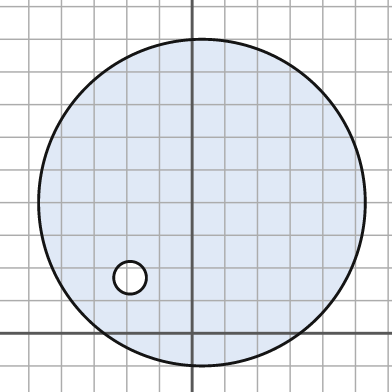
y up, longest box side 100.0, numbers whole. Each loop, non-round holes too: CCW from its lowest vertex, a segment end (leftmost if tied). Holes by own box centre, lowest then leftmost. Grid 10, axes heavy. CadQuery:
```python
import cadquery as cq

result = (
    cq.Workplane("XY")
    .moveTo(3.0, 40.0)
    .circle(50.0)
    .moveTo(-19.0, 17.0)
    .circle(5.0)
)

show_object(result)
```